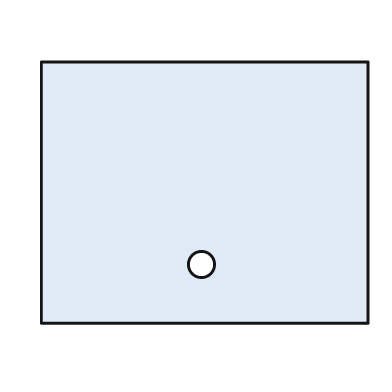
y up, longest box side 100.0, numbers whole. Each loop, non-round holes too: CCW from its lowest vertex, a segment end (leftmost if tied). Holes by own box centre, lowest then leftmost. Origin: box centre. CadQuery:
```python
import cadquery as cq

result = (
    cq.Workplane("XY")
    .moveTo(-50.0, -40.0)
    .lineTo(50.0, -40.0)
    .lineTo(50.0, 40.0)
    .lineTo(-50.0, 40.0)
    .close()
    .moveTo(-1.0, -22.0)
    .circle(4.0)
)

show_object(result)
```